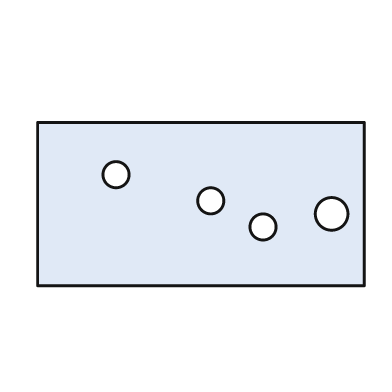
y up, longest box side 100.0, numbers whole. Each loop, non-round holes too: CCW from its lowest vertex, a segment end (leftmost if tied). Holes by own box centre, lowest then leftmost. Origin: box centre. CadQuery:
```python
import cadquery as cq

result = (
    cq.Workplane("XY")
    .moveTo(-50.0, -25.0)
    .lineTo(50.0, -25.0)
    .lineTo(50.0, 25.0)
    .lineTo(-50.0, 25.0)
    .close()
    .moveTo(19.0, -7.0)
    .circle(4.0)
    .moveTo(40.0, -3.0)
    .circle(5.0)
    .moveTo(3.0, 1.0)
    .circle(4.0)
    .moveTo(-26.0, 9.0)
    .circle(4.0)
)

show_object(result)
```